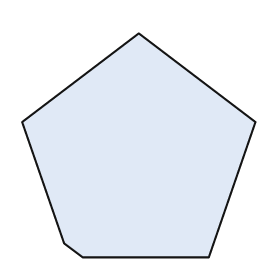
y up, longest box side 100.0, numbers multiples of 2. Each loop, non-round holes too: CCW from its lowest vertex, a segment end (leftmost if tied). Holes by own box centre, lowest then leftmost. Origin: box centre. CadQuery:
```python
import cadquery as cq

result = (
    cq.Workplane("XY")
    .moveTo(-24.0, -48.0)
    .lineTo(30.0, -48.0)
    .lineTo(50.0, 10.0)
    .lineTo(0.0, 48.0)
    .lineTo(-50.0, 10.0)
    .lineTo(-32.0, -42.0)
    .close()
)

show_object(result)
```